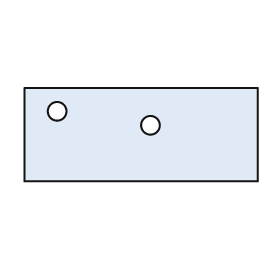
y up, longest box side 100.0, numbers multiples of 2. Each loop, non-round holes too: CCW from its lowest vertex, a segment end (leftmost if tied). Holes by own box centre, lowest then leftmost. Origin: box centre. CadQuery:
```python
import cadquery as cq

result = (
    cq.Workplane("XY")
    .moveTo(-50.0, -20.0)
    .lineTo(50.0, -20.0)
    .lineTo(50.0, 20.0)
    .lineTo(-50.0, 20.0)
    .close()
    .moveTo(4.0, 4.0)
    .circle(4.0)
    .moveTo(-36.0, 10.0)
    .circle(4.0)
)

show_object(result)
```